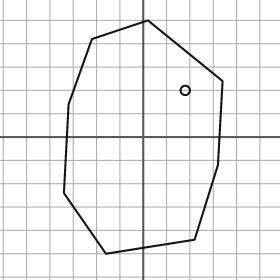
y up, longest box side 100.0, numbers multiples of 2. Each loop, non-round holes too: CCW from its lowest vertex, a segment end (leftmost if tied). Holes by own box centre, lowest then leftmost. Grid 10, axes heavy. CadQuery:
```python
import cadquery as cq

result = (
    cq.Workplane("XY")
    .moveTo(-16.0, -50.0)
    .lineTo(22.0, -44.0)
    .lineTo(32.0, -12.0)
    .lineTo(34.0, 24.0)
    .lineTo(2.0, 50.0)
    .lineTo(-22.0, 42.0)
    .lineTo(-32.0, 14.0)
    .lineTo(-34.0, -24.0)
    .close()
    .moveTo(18.0, 20.0)
    .circle(2.0)
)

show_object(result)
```